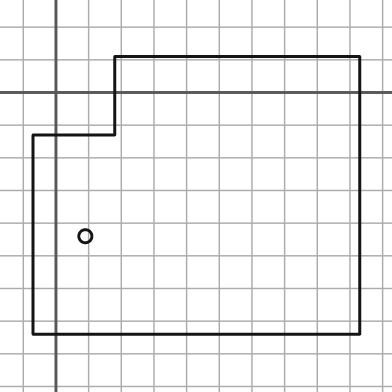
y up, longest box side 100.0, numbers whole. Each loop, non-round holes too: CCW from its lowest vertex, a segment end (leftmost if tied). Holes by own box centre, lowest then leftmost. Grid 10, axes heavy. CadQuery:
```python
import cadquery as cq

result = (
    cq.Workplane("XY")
    .moveTo(-7.0, -74.0)
    .lineTo(93.0, -74.0)
    .lineTo(93.0, 11.0)
    .lineTo(18.0, 11.0)
    .lineTo(18.0, -13.0)
    .lineTo(-7.0, -13.0)
    .close()
    .moveTo(9.0, -44.0)
    .circle(2.0)
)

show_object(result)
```